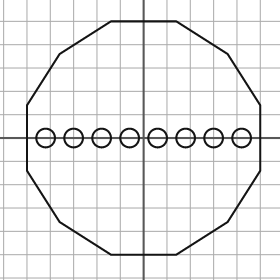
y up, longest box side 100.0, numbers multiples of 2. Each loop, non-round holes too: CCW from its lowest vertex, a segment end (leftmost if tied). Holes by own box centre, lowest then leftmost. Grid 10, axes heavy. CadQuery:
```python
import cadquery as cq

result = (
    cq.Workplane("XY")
    .moveTo(-14.0, -50.0)
    .lineTo(14.0, -50.0)
    .lineTo(36.0, -36.0)
    .lineTo(50.0, -14.0)
    .lineTo(50.0, 14.0)
    .lineTo(36.0, 36.0)
    .lineTo(14.0, 50.0)
    .lineTo(-14.0, 50.0)
    .lineTo(-36.0, 36.0)
    .lineTo(-50.0, 14.0)
    .lineTo(-50.0, -14.0)
    .lineTo(-36.0, -36.0)
    .close()
    .moveTo(-42.0, 0.0)
    .circle(4.0)
    .moveTo(-30.0, 0.0)
    .circle(4.0)
    .moveTo(-18.0, 0.0)
    .circle(4.0)
    .moveTo(-6.0, 0.0)
    .circle(4.0)
    .moveTo(6.0, 0.0)
    .circle(4.0)
    .moveTo(18.0, 0.0)
    .circle(4.0)
    .moveTo(30.0, 0.0)
    .circle(4.0)
    .moveTo(42.0, 0.0)
    .circle(4.0)
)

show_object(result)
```